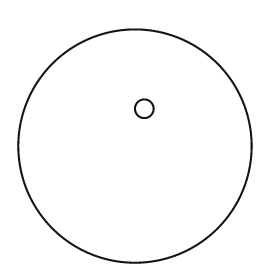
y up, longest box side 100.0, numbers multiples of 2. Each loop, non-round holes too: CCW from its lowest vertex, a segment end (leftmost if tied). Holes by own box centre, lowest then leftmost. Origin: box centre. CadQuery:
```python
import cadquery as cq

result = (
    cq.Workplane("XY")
    .moveTo(0.0, 0.0)
    .circle(50.0)
    .moveTo(4.0, 16.0)
    .circle(4.0)
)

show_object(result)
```